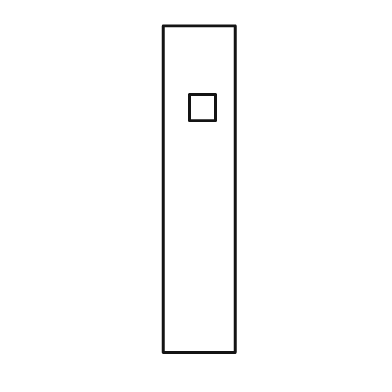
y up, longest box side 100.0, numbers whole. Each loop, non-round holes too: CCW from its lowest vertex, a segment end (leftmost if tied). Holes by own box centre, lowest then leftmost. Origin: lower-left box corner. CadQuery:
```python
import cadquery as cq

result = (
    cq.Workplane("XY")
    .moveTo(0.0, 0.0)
    .lineTo(22.0, 0.0)
    .lineTo(22.0, 100.0)
    .lineTo(0.0, 100.0)
    .close()
    .moveTo(8.0, 71.0)
    .lineTo(16.0, 71.0)
    .lineTo(16.0, 79.0)
    .lineTo(8.0, 79.0)
    .close()
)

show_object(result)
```